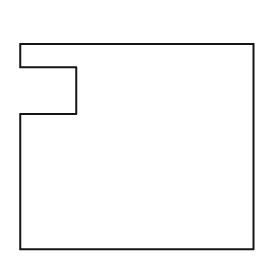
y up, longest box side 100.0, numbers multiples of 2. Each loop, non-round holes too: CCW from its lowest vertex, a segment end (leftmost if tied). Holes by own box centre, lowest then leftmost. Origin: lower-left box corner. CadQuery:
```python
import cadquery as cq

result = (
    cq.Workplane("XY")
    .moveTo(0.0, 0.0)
    .lineTo(100.0, 0.0)
    .lineTo(100.0, 88.0)
    .lineTo(0.0, 88.0)
    .lineTo(0.0, 78.0)
    .lineTo(24.0, 78.0)
    .lineTo(24.0, 58.0)
    .lineTo(0.0, 58.0)
    .close()
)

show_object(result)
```